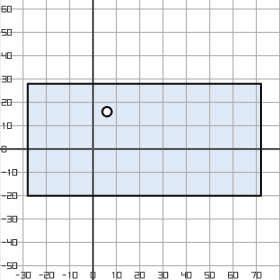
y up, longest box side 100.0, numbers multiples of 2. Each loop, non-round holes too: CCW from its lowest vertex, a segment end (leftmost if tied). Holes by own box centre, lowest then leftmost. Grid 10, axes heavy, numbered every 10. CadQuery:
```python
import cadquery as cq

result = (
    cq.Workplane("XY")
    .moveTo(-28.0, -20.0)
    .lineTo(72.0, -20.0)
    .lineTo(72.0, 28.0)
    .lineTo(-28.0, 28.0)
    .close()
    .moveTo(6.0, 16.0)
    .circle(2.0)
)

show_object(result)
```